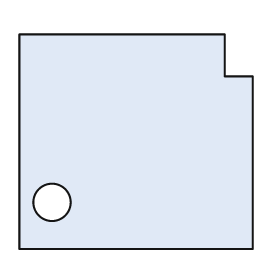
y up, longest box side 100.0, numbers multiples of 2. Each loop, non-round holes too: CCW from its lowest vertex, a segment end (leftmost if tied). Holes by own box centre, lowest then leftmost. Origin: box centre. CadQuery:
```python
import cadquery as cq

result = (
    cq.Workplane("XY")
    .moveTo(-50.0, -46.0)
    .lineTo(50.0, -46.0)
    .lineTo(50.0, 28.0)
    .lineTo(38.0, 28.0)
    .lineTo(38.0, 46.0)
    .lineTo(-50.0, 46.0)
    .close()
    .moveTo(-36.0, -26.0)
    .circle(8.0)
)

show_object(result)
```